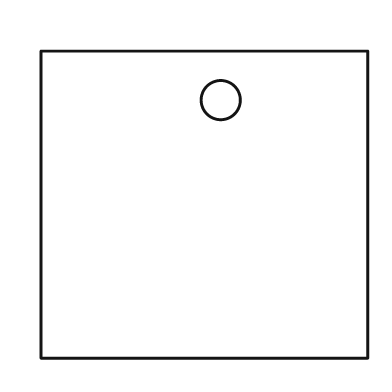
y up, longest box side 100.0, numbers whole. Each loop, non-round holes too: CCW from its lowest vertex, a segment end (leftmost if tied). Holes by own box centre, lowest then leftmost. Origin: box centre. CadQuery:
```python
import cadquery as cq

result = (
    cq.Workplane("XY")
    .moveTo(-50.0, -47.0)
    .lineTo(50.0, -47.0)
    .lineTo(50.0, 47.0)
    .lineTo(-50.0, 47.0)
    .close()
    .moveTo(5.0, 32.0)
    .circle(6.0)
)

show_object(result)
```